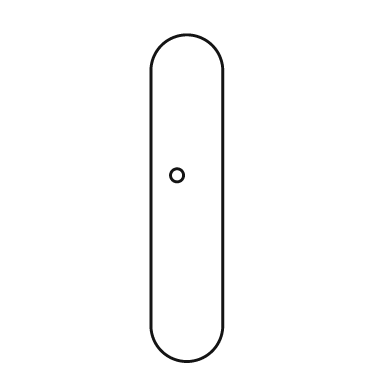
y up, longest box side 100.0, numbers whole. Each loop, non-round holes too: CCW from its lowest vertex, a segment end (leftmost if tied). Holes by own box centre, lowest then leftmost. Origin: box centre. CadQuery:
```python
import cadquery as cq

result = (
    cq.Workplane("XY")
    .moveTo(-11.0, -39.0)
    .threePointArc((0.0, -50.0), (11.0, -39.0))
    .lineTo(11.0, 39.0)
    .threePointArc((0.0, 50.0), (-11.0, 39.0))
    .close()
    .moveTo(-3.0, 7.0)
    .circle(2.0)
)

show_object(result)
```